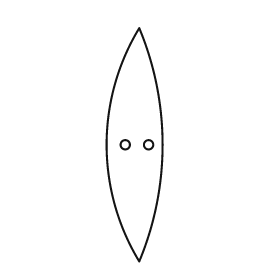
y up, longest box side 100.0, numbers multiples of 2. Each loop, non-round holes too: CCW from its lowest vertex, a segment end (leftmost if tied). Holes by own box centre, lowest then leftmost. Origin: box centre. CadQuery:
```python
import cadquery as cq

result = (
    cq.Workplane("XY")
    .moveTo(2.0, -50.0)
    .threePointArc((12.0, 0.0), (2.0, 50.0))
    .threePointArc((-12.0, 0.0), (2.0, -50.0))
    .close()
    .moveTo(-4.0, 0.0)
    .circle(2.0)
    .moveTo(6.0, 0.0)
    .circle(2.0)
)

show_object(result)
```